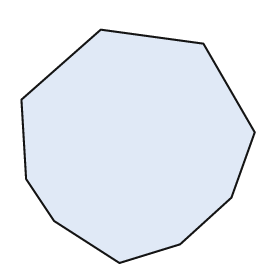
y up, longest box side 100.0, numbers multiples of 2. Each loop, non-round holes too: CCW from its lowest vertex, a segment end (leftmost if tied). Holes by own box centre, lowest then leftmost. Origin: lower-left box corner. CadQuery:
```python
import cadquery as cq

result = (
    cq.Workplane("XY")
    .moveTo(42.0, 0.0)
    .lineTo(68.0, 8.0)
    .lineTo(90.0, 28.0)
    .lineTo(100.0, 56.0)
    .lineTo(78.0, 94.0)
    .lineTo(34.0, 100.0)
    .lineTo(0.0, 70.0)
    .lineTo(2.0, 36.0)
    .lineTo(14.0, 18.0)
    .close()
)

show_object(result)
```